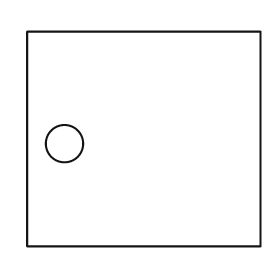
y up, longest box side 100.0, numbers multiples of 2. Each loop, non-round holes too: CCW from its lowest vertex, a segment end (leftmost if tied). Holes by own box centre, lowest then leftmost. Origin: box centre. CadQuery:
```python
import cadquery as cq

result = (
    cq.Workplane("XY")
    .moveTo(-50.0, -46.0)
    .lineTo(50.0, -46.0)
    .lineTo(50.0, 46.0)
    .lineTo(-50.0, 46.0)
    .close()
    .moveTo(-34.0, -2.0)
    .circle(8.0)
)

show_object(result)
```